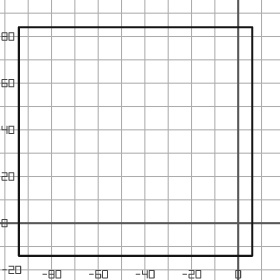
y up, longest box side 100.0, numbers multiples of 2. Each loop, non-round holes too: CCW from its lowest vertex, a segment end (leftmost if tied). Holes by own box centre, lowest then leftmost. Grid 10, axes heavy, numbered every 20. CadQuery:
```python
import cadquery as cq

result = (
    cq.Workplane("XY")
    .moveTo(-94.0, -14.0)
    .lineTo(6.0, -14.0)
    .lineTo(6.0, 84.0)
    .lineTo(-94.0, 84.0)
    .close()
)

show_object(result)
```